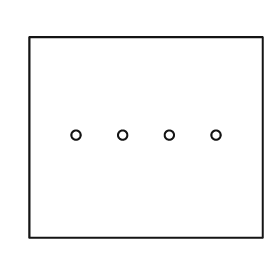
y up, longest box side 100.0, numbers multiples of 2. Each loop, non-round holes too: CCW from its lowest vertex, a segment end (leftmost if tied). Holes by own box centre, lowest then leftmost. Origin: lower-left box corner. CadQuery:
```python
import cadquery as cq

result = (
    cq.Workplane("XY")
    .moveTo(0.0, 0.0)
    .lineTo(100.0, 0.0)
    .lineTo(100.0, 86.0)
    .lineTo(0.0, 86.0)
    .close()
    .moveTo(20.0, 44.0)
    .circle(2.0)
    .moveTo(40.0, 44.0)
    .circle(2.0)
    .moveTo(60.0, 44.0)
    .circle(2.0)
    .moveTo(80.0, 44.0)
    .circle(2.0)
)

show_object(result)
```